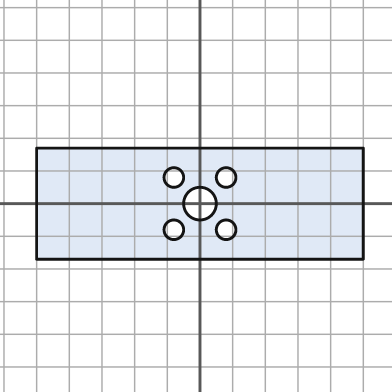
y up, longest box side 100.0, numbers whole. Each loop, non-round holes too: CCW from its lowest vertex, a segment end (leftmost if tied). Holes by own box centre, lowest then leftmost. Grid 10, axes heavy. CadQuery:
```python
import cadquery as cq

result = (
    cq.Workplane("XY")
    .moveTo(-50.0, -17.0)
    .lineTo(50.0, -17.0)
    .lineTo(50.0, 17.0)
    .lineTo(-50.0, 17.0)
    .close()
    .moveTo(-8.0, -8.0)
    .circle(3.0)
    .moveTo(8.0, -8.0)
    .circle(3.0)
    .moveTo(0.0, 0.0)
    .circle(5.0)
    .moveTo(-8.0, 8.0)
    .circle(3.0)
    .moveTo(8.0, 8.0)
    .circle(3.0)
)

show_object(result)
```